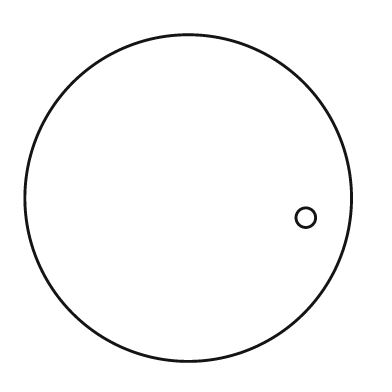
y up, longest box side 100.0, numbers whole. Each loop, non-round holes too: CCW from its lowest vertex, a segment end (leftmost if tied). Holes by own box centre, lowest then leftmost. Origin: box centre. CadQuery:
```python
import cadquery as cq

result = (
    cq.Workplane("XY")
    .moveTo(0.0, 0.0)
    .circle(50.0)
    .moveTo(36.0, -6.0)
    .circle(3.0)
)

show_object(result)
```